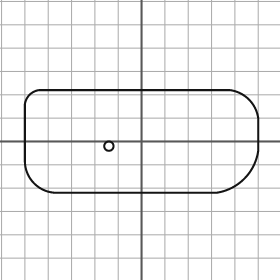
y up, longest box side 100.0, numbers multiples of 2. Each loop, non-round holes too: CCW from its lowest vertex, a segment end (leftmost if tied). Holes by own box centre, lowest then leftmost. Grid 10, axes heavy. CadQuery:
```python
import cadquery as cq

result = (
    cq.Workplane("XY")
    .moveTo(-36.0, -22.0)
    .lineTo(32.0, -22.0)
    .threePointArc((44.0, -16.0), (50.0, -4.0))
    .lineTo(50.0, 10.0)
    .threePointArc((46.0, 18.0), (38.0, 22.0))
    .lineTo(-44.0, 22.0)
    .threePointArc((-48.0, 20.0), (-50.0, 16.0))
    .lineTo(-50.0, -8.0)
    .threePointArc((-46.0, -18.0), (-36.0, -22.0))
    .close()
    .moveTo(-14.0, -2.0)
    .circle(2.0)
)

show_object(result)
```